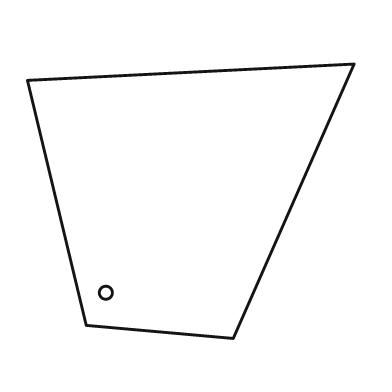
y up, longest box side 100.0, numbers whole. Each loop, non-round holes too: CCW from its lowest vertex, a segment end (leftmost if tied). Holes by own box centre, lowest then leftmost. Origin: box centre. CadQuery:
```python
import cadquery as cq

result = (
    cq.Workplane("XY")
    .moveTo(13.0, -42.0)
    .lineTo(50.0, 42.0)
    .lineTo(-50.0, 37.0)
    .lineTo(-32.0, -38.0)
    .close()
    .moveTo(-26.0, -28.0)
    .circle(2.0)
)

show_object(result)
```